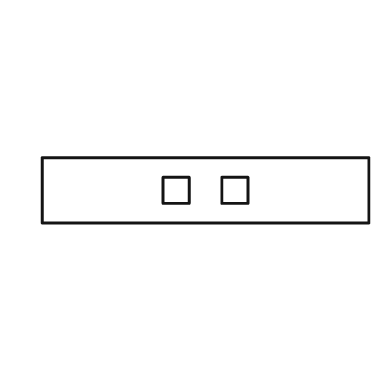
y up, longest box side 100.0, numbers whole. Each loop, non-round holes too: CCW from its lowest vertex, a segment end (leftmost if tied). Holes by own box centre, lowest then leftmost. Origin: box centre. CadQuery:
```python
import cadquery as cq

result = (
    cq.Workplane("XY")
    .moveTo(-50.0, -10.0)
    .lineTo(50.0, -10.0)
    .lineTo(50.0, 10.0)
    .lineTo(-50.0, 10.0)
    .close()
    .moveTo(-13.0, -4.0)
    .lineTo(-5.0, -4.0)
    .lineTo(-5.0, 4.0)
    .lineTo(-13.0, 4.0)
    .close()
    .moveTo(5.0, -4.0)
    .lineTo(13.0, -4.0)
    .lineTo(13.0, 4.0)
    .lineTo(5.0, 4.0)
    .close()
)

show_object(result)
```